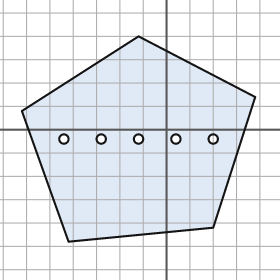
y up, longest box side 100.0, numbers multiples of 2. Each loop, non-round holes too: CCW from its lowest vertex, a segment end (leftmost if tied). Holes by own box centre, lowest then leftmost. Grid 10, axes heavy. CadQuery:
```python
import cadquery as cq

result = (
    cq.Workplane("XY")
    .moveTo(-42.0, -48.0)
    .lineTo(20.0, -42.0)
    .lineTo(38.0, 14.0)
    .lineTo(-12.0, 40.0)
    .lineTo(-62.0, 8.0)
    .close()
    .moveTo(-44.0, -4.0)
    .circle(2.0)
    .moveTo(-28.0, -4.0)
    .circle(2.0)
    .moveTo(-12.0, -4.0)
    .circle(2.0)
    .moveTo(4.0, -4.0)
    .circle(2.0)
    .moveTo(20.0, -4.0)
    .circle(2.0)
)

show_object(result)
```